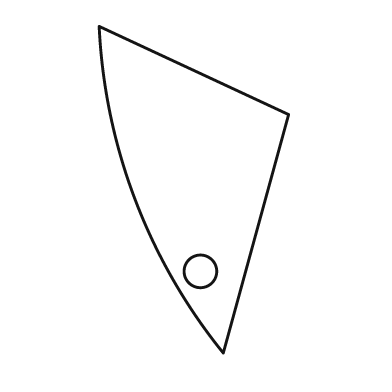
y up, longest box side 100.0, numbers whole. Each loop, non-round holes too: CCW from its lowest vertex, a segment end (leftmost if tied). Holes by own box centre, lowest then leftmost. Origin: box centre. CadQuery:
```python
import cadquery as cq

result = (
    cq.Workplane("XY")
    .moveTo(9.0, -50.0)
    .lineTo(29.0, 23.0)
    .lineTo(-29.0, 50.0)
    .threePointArc((-18.0, -3.0), (9.0, -50.0))
    .close()
    .moveTo(2.0, -25.0)
    .circle(5.0)
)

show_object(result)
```